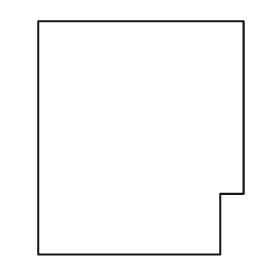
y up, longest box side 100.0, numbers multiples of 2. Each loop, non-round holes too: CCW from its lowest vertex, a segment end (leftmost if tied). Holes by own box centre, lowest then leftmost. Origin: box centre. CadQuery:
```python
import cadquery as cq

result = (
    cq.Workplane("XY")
    .moveTo(-44.0, -50.0)
    .lineTo(34.0, -50.0)
    .lineTo(34.0, -24.0)
    .lineTo(44.0, -24.0)
    .lineTo(44.0, 50.0)
    .lineTo(-44.0, 50.0)
    .close()
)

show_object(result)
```